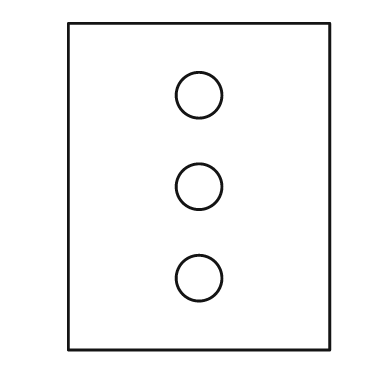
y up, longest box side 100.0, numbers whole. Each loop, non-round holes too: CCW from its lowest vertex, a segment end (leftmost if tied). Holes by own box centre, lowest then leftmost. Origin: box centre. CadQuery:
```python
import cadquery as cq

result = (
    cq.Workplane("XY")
    .moveTo(-40.0, -50.0)
    .lineTo(40.0, -50.0)
    .lineTo(40.0, 50.0)
    .lineTo(-40.0, 50.0)
    .close()
    .moveTo(0.0, -28.0)
    .circle(7.0)
    .moveTo(0.0, 0.0)
    .circle(7.0)
    .moveTo(0.0, 28.0)
    .circle(7.0)
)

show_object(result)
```